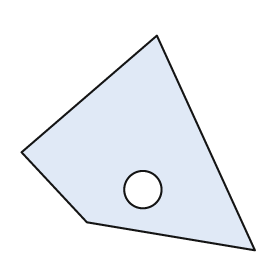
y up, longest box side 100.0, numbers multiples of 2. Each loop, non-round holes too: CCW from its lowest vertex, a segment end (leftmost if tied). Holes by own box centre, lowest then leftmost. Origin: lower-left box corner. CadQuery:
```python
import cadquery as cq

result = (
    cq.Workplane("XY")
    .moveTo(100.0, 0.0)
    .lineTo(58.0, 92.0)
    .lineTo(0.0, 42.0)
    .lineTo(28.0, 12.0)
    .close()
    .moveTo(52.0, 26.0)
    .circle(8.0)
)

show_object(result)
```